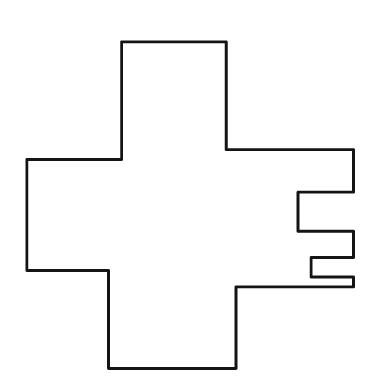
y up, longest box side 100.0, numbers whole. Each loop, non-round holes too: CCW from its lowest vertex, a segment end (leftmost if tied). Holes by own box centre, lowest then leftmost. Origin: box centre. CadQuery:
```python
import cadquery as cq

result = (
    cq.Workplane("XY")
    .moveTo(-25.0, -50.0)
    .lineTo(14.0, -50.0)
    .lineTo(14.0, -25.0)
    .lineTo(50.0, -25.0)
    .lineTo(50.0, -22.0)
    .lineTo(37.0, -22.0)
    .lineTo(37.0, -16.0)
    .lineTo(50.0, -16.0)
    .lineTo(50.0, -8.0)
    .lineTo(33.0, -8.0)
    .lineTo(33.0, 4.0)
    .lineTo(50.0, 4.0)
    .lineTo(50.0, 17.0)
    .lineTo(11.0, 17.0)
    .lineTo(11.0, 50.0)
    .lineTo(-21.0, 50.0)
    .lineTo(-21.0, 14.0)
    .lineTo(-50.0, 14.0)
    .lineTo(-50.0, -20.0)
    .lineTo(-25.0, -20.0)
    .close()
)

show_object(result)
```